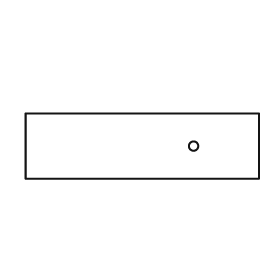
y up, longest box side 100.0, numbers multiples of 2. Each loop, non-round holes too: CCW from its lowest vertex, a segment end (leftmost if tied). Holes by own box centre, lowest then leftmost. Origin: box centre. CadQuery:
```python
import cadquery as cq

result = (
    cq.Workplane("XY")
    .moveTo(-50.0, -14.0)
    .lineTo(50.0, -14.0)
    .lineTo(50.0, 14.0)
    .lineTo(-50.0, 14.0)
    .close()
    .moveTo(22.0, 0.0)
    .circle(2.0)
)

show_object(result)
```